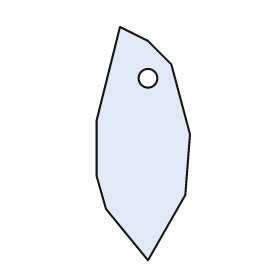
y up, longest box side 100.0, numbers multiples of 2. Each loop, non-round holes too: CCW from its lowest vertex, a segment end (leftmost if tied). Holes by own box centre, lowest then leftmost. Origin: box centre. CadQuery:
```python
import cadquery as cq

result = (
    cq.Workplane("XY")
    .moveTo(2.0, -50.0)
    .lineTo(18.0, -22.0)
    .lineTo(20.0, 4.0)
    .lineTo(12.0, 34.0)
    .lineTo(2.0, 44.0)
    .lineTo(-10.0, 50.0)
    .lineTo(-20.0, 10.0)
    .lineTo(-20.0, -14.0)
    .lineTo(-16.0, -28.0)
    .close()
    .moveTo(2.0, 28.0)
    .circle(4.0)
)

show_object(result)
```